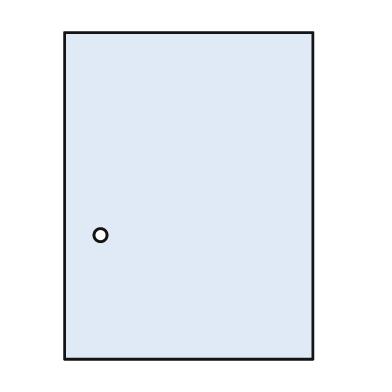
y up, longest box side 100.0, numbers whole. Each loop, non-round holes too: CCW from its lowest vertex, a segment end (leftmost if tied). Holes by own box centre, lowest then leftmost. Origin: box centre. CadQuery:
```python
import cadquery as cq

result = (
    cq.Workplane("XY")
    .moveTo(-38.0, -50.0)
    .lineTo(38.0, -50.0)
    .lineTo(38.0, 50.0)
    .lineTo(-38.0, 50.0)
    .close()
    .moveTo(-27.0, -12.0)
    .circle(2.0)
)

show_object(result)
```